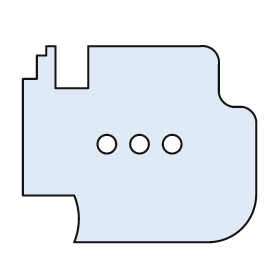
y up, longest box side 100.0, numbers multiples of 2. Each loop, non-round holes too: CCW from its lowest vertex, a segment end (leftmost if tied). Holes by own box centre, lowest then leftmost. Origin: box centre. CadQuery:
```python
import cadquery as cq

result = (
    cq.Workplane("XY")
    .moveTo(-28.0, -42.0)
    .lineTo(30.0, -42.0)
    .threePointArc((44.0, -36.0), (50.0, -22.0))
    .lineTo(50.0, 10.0)
    .threePointArc((48.0, 14.0), (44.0, 16.0))
    .lineTo(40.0, 16.0)
    .threePointArc((36.0, 18.0), (34.0, 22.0))
    .lineTo(34.0, 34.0)
    .threePointArc((32.0, 40.0), (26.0, 42.0))
    .lineTo(-22.0, 42.0)
    .lineTo(-22.0, 24.0)
    .lineTo(-36.0, 24.0)
    .lineTo(-36.0, 42.0)
    .lineTo(-40.0, 42.0)
    .lineTo(-40.0, 38.0)
    .lineTo(-44.0, 38.0)
    .lineTo(-44.0, 28.0)
    .lineTo(-50.0, 28.0)
    .lineTo(-50.0, -22.0)
    .lineTo(-28.0, -22.0)
    .threePointArc((-26.0, -32.0), (-28.0, -42.0))
    .close()
    .moveTo(-14.0, 0.0)
    .circle(4.0)
    .moveTo(0.0, 0.0)
    .circle(4.0)
    .moveTo(14.0, 0.0)
    .circle(4.0)
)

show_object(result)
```